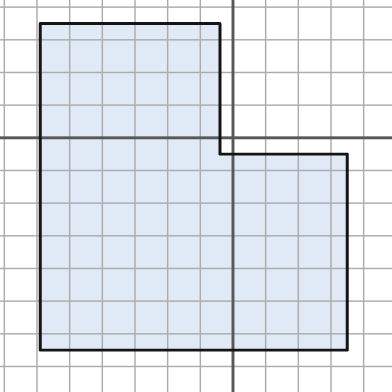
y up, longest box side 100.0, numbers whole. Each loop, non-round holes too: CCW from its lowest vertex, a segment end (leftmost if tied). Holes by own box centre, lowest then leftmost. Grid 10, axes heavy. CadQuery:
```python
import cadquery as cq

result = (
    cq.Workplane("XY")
    .moveTo(-59.0, -65.0)
    .lineTo(35.0, -65.0)
    .lineTo(35.0, -5.0)
    .lineTo(-4.0, -5.0)
    .lineTo(-4.0, 35.0)
    .lineTo(-59.0, 35.0)
    .close()
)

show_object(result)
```